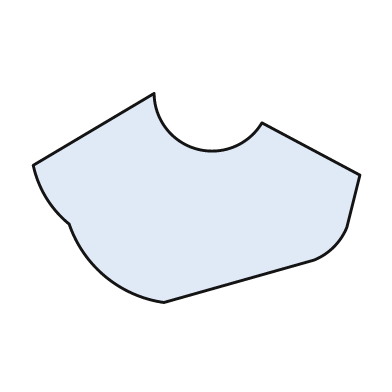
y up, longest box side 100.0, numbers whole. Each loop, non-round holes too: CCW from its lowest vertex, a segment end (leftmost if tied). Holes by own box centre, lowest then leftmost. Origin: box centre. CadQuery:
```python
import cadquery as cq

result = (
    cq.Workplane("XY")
    .moveTo(-10.0, -32.0)
    .lineTo(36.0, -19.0)
    .threePointArc((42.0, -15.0), (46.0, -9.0))
    .lineTo(50.0, 7.0)
    .lineTo(20.0, 23.0)
    .threePointArc((0.0, 15.0), (-13.0, 32.0))
    .lineTo(-50.0, 10.0)
    .threePointArc((-46.0, 0.0), (-39.0, -8.0))
    .threePointArc((-28.0, -24.0), (-10.0, -32.0))
    .close()
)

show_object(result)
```